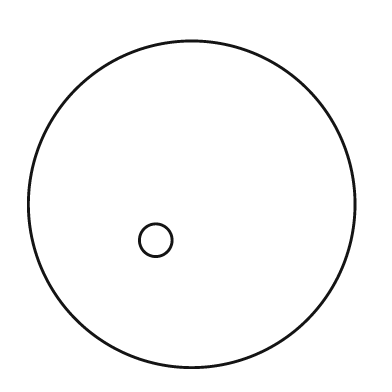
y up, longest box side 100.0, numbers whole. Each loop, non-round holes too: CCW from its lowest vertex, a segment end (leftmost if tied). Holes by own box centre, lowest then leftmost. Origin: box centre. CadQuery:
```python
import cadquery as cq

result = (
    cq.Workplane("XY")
    .moveTo(0.0, 0.0)
    .circle(50.0)
    .moveTo(-11.0, -11.0)
    .circle(5.0)
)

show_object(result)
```